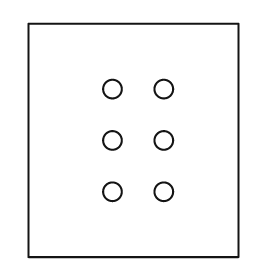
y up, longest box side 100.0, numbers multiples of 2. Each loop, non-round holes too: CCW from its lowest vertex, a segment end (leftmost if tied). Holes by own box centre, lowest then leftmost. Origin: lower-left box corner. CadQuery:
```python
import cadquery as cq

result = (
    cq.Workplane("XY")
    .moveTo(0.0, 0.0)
    .lineTo(90.0, 0.0)
    .lineTo(90.0, 100.0)
    .lineTo(0.0, 100.0)
    .close()
    .moveTo(36.0, 28.0)
    .circle(4.0)
    .moveTo(58.0, 28.0)
    .circle(4.0)
    .moveTo(36.0, 50.0)
    .circle(4.0)
    .moveTo(58.0, 50.0)
    .circle(4.0)
    .moveTo(36.0, 72.0)
    .circle(4.0)
    .moveTo(58.0, 72.0)
    .circle(4.0)
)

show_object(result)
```